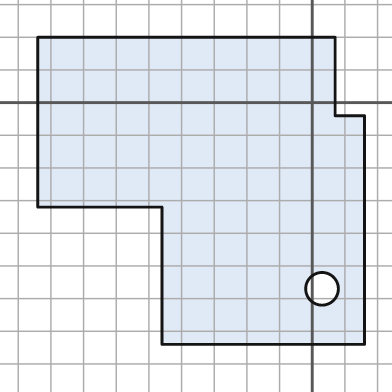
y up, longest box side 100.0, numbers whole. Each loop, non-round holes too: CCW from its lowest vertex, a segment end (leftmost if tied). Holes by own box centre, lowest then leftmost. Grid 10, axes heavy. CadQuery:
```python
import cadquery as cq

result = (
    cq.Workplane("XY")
    .moveTo(-46.0, -74.0)
    .lineTo(16.0, -74.0)
    .lineTo(16.0, -4.0)
    .lineTo(7.0, -4.0)
    .lineTo(7.0, 20.0)
    .lineTo(-84.0, 20.0)
    .lineTo(-84.0, -32.0)
    .lineTo(-46.0, -32.0)
    .close()
    .moveTo(3.0, -57.0)
    .circle(5.0)
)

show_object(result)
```